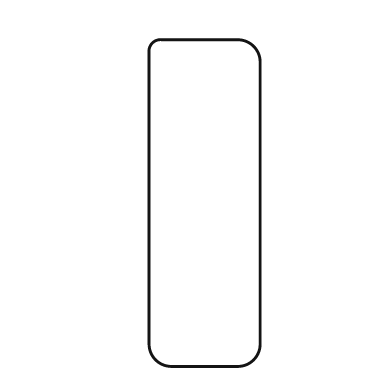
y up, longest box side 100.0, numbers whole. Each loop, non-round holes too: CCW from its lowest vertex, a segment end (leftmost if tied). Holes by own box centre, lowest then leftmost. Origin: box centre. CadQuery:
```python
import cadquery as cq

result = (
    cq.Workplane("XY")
    .moveTo(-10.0, -50.0)
    .lineTo(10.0, -50.0)
    .threePointArc((15.0, -48.0), (17.0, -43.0))
    .lineTo(17.0, 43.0)
    .threePointArc((15.0, 48.0), (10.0, 50.0))
    .lineTo(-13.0, 50.0)
    .threePointArc((-16.0, 49.0), (-17.0, 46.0))
    .lineTo(-17.0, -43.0)
    .threePointArc((-15.0, -48.0), (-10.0, -50.0))
    .close()
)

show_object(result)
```